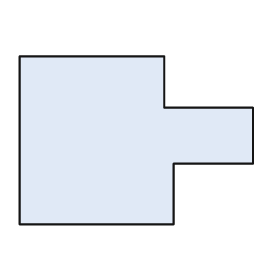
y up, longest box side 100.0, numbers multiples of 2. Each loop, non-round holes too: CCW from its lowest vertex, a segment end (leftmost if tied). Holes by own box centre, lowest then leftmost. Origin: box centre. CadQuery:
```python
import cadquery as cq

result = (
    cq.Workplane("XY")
    .moveTo(-50.0, -36.0)
    .lineTo(16.0, -36.0)
    .lineTo(16.0, -10.0)
    .lineTo(50.0, -10.0)
    .lineTo(50.0, 14.0)
    .lineTo(12.0, 14.0)
    .lineTo(12.0, 36.0)
    .lineTo(-50.0, 36.0)
    .close()
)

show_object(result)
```